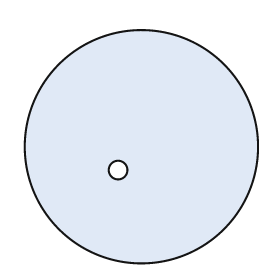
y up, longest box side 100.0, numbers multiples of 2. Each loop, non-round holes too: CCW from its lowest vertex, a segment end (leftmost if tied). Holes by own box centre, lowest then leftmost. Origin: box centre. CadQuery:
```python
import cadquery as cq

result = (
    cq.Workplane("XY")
    .moveTo(0.0, 0.0)
    .circle(50.0)
    .moveTo(-10.0, -10.0)
    .circle(4.0)
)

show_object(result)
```